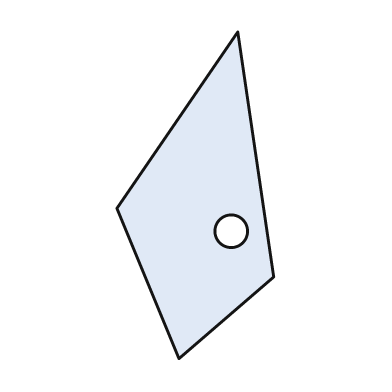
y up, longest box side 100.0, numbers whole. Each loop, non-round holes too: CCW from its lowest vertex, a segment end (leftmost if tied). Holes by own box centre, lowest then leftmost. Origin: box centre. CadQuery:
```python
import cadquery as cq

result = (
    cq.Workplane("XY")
    .moveTo(-5.0, -50.0)
    .lineTo(24.0, -25.0)
    .lineTo(13.0, 50.0)
    .lineTo(-24.0, -4.0)
    .close()
    .moveTo(11.0, -11.0)
    .circle(5.0)
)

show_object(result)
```